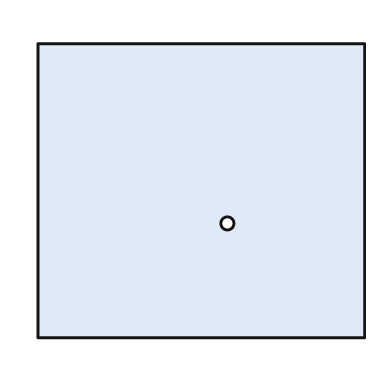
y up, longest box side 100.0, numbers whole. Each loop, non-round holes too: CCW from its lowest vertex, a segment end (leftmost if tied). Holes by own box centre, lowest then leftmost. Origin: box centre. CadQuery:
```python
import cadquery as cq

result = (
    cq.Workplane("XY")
    .moveTo(-50.0, -45.0)
    .lineTo(50.0, -45.0)
    .lineTo(50.0, 45.0)
    .lineTo(-50.0, 45.0)
    .close()
    .moveTo(8.0, -10.0)
    .circle(2.0)
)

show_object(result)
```